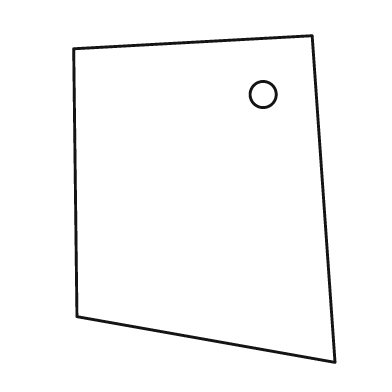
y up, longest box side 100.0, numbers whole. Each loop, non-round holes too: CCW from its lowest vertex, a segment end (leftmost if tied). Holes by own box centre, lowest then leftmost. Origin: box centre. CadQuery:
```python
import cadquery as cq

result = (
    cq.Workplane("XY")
    .moveTo(40.0, -50.0)
    .lineTo(33.0, 50.0)
    .lineTo(-40.0, 46.0)
    .lineTo(-39.0, -36.0)
    .close()
    .moveTo(18.0, 32.0)
    .circle(4.0)
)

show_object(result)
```